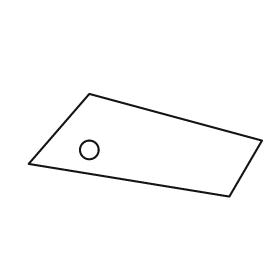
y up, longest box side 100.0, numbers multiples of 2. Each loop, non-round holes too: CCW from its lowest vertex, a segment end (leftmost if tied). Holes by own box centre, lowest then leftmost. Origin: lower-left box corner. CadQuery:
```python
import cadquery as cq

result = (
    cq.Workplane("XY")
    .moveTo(86.0, 0.0)
    .lineTo(100.0, 24.0)
    .lineTo(26.0, 44.0)
    .lineTo(0.0, 14.0)
    .close()
    .moveTo(26.0, 20.0)
    .circle(4.0)
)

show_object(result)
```